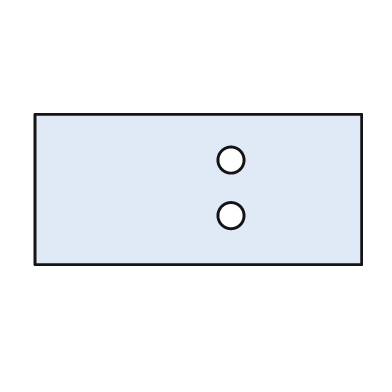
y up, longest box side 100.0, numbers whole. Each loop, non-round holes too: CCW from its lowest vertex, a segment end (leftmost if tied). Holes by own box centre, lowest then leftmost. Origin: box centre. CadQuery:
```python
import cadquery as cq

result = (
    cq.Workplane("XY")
    .moveTo(-50.0, -23.0)
    .lineTo(50.0, -23.0)
    .lineTo(50.0, 23.0)
    .lineTo(-50.0, 23.0)
    .close()
    .moveTo(10.0, -8.0)
    .circle(4.0)
    .moveTo(10.0, 9.0)
    .circle(4.0)
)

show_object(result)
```